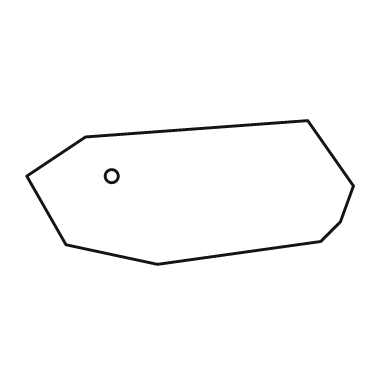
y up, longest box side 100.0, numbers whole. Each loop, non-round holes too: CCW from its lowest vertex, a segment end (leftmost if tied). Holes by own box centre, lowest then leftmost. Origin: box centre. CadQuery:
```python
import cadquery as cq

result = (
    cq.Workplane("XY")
    .moveTo(-10.0, -22.0)
    .lineTo(40.0, -15.0)
    .lineTo(46.0, -9.0)
    .lineTo(50.0, 2.0)
    .lineTo(36.0, 22.0)
    .lineTo(-32.0, 17.0)
    .lineTo(-50.0, 5.0)
    .lineTo(-38.0, -16.0)
    .close()
    .moveTo(-24.0, 5.0)
    .circle(2.0)
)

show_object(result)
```